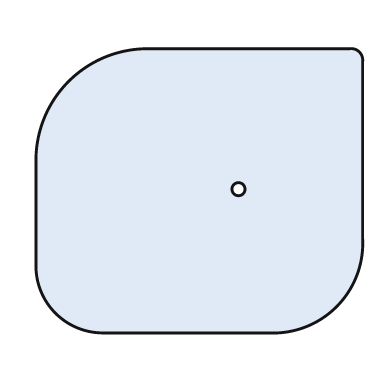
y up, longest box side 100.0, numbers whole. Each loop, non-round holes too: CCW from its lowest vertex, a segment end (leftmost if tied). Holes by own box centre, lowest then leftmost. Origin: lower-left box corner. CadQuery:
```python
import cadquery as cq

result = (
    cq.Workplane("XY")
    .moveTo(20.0, 0.0)
    .lineTo(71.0, 0.0)
    .threePointArc((92.0, 8.0), (100.0, 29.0))
    .lineTo(100.0, 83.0)
    .threePointArc((99.0, 86.0), (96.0, 87.0))
    .lineTo(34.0, 87.0)
    .threePointArc((10.0, 77.0), (0.0, 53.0))
    .lineTo(0.0, 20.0)
    .threePointArc((6.0, 6.0), (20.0, 0.0))
    .close()
    .moveTo(62.0, 44.0)
    .circle(2.0)
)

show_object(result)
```